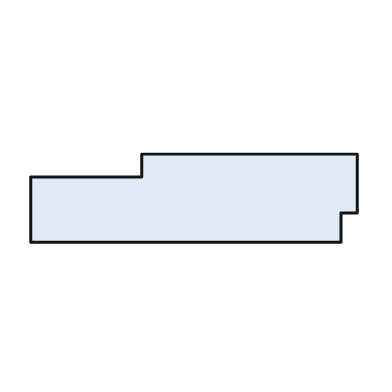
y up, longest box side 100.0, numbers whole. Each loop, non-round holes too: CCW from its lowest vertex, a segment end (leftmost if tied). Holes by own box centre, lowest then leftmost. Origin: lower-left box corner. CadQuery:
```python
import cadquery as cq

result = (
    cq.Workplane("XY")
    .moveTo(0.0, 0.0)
    .lineTo(95.0, 0.0)
    .lineTo(95.0, 9.0)
    .lineTo(100.0, 9.0)
    .lineTo(100.0, 27.0)
    .lineTo(34.0, 27.0)
    .lineTo(34.0, 20.0)
    .lineTo(0.0, 20.0)
    .close()
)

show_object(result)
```